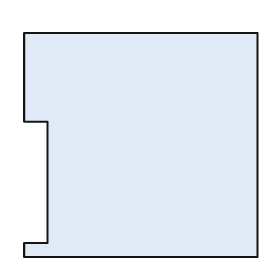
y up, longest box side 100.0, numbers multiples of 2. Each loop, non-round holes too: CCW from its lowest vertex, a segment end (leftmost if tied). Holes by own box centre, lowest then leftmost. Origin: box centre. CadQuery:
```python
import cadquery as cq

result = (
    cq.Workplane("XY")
    .moveTo(-50.0, -48.0)
    .lineTo(50.0, -48.0)
    .lineTo(50.0, 48.0)
    .lineTo(-50.0, 48.0)
    .lineTo(-50.0, 10.0)
    .lineTo(-40.0, 10.0)
    .lineTo(-40.0, -42.0)
    .lineTo(-50.0, -42.0)
    .close()
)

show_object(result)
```